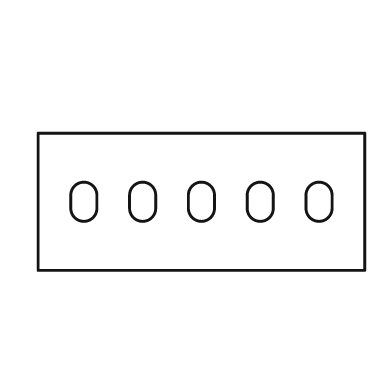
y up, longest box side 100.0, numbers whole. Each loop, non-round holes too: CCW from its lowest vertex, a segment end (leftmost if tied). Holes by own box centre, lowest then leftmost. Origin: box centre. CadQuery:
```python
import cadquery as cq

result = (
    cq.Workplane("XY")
    .moveTo(-50.0, -21.0)
    .lineTo(50.0, -21.0)
    .lineTo(50.0, 21.0)
    .lineTo(-50.0, 21.0)
    .close()
    .moveTo(-40.0, -2.0)
    .threePointArc((-36.0, -6.0), (-32.0, -2.0))
    .lineTo(-32.0, 2.0)
    .threePointArc((-36.0, 6.0), (-40.0, 2.0))
    .close()
    .moveTo(-22.0, -2.0)
    .threePointArc((-18.0, -6.0), (-14.0, -2.0))
    .lineTo(-14.0, 2.0)
    .threePointArc((-18.0, 6.0), (-22.0, 2.0))
    .close()
    .moveTo(-4.0, -2.0)
    .threePointArc((0.0, -6.0), (4.0, -2.0))
    .lineTo(4.0, 2.0)
    .threePointArc((0.0, 6.0), (-4.0, 2.0))
    .close()
    .moveTo(14.0, -2.0)
    .threePointArc((18.0, -6.0), (22.0, -2.0))
    .lineTo(22.0, 2.0)
    .threePointArc((18.0, 6.0), (14.0, 2.0))
    .close()
    .moveTo(32.0, -2.0)
    .threePointArc((36.0, -6.0), (40.0, -2.0))
    .lineTo(40.0, 2.0)
    .threePointArc((36.0, 6.0), (32.0, 2.0))
    .close()
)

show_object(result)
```